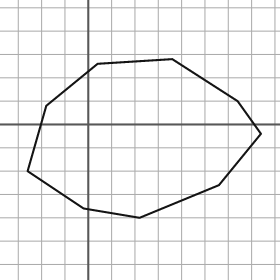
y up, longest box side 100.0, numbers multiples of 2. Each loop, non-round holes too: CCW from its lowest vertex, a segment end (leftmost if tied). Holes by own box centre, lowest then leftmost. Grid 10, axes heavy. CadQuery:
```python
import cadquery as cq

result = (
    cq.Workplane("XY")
    .moveTo(22.0, -40.0)
    .lineTo(56.0, -26.0)
    .lineTo(74.0, -4.0)
    .lineTo(64.0, 10.0)
    .lineTo(36.0, 28.0)
    .lineTo(4.0, 26.0)
    .lineTo(-18.0, 8.0)
    .lineTo(-26.0, -20.0)
    .lineTo(-2.0, -36.0)
    .close()
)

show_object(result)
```